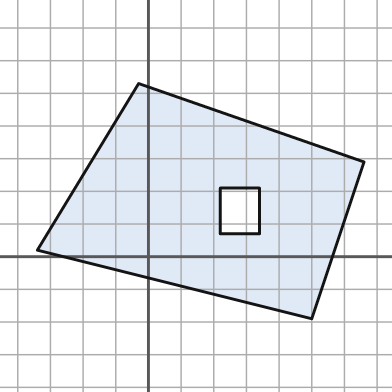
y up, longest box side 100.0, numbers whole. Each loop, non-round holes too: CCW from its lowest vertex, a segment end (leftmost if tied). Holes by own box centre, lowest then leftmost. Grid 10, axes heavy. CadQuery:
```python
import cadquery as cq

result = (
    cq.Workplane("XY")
    .moveTo(50.0, -19.0)
    .lineTo(66.0, 29.0)
    .lineTo(-3.0, 53.0)
    .lineTo(-34.0, 2.0)
    .close()
    .moveTo(22.0, 7.0)
    .lineTo(34.0, 7.0)
    .lineTo(34.0, 21.0)
    .lineTo(22.0, 21.0)
    .close()
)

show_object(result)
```